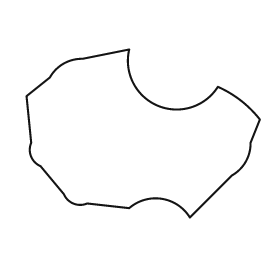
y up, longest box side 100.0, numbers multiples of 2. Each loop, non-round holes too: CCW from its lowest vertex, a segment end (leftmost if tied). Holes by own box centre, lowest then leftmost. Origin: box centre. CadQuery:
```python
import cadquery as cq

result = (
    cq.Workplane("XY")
    .moveTo(20.0, -36.0)
    .lineTo(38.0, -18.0)
    .threePointArc((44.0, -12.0), (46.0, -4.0))
    .lineTo(50.0, 6.0)
    .threePointArc((42.0, 14.0), (32.0, 20.0))
    .threePointArc((6.0, 12.0), (-6.0, 36.0))
    .lineTo(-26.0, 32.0)
    .threePointArc((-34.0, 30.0), (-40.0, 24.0))
    .lineTo(-50.0, 16.0)
    .lineTo(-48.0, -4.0)
    .threePointArc((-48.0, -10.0), (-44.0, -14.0))
    .lineTo(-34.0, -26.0)
    .threePointArc((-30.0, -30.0), (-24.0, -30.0))
    .lineTo(-6.0, -32.0)
    .threePointArc((8.0, -28.0), (20.0, -36.0))
    .close()
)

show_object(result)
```